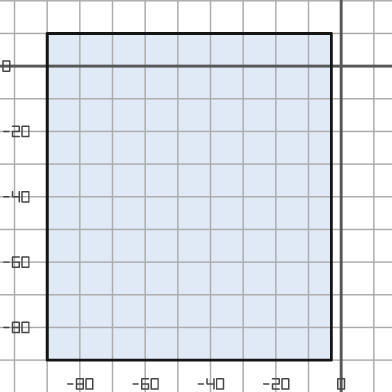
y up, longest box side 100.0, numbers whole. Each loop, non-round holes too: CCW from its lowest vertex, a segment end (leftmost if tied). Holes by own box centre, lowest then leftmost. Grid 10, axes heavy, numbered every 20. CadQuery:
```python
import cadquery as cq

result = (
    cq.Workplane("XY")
    .moveTo(-90.0, -90.0)
    .lineTo(-3.0, -90.0)
    .lineTo(-3.0, 10.0)
    .lineTo(-90.0, 10.0)
    .close()
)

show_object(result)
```